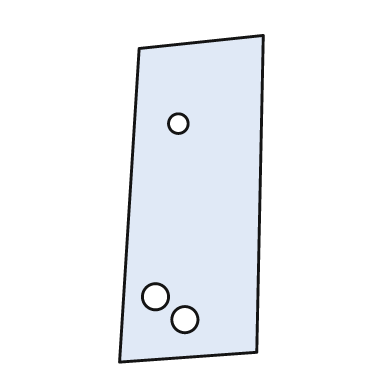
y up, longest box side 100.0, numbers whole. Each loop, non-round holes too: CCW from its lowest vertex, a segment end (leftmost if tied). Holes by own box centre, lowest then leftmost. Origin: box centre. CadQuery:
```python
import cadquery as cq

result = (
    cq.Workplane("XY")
    .moveTo(-22.0, -50.0)
    .lineTo(20.0, -47.0)
    .lineTo(22.0, 50.0)
    .lineTo(-16.0, 46.0)
    .close()
    .moveTo(-2.0, -37.0)
    .circle(4.0)
    .moveTo(-11.0, -30.0)
    .circle(4.0)
    .moveTo(-4.0, 23.0)
    .circle(3.0)
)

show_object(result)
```